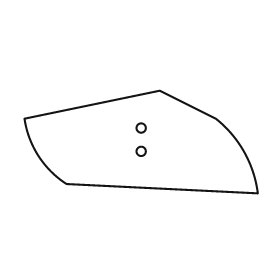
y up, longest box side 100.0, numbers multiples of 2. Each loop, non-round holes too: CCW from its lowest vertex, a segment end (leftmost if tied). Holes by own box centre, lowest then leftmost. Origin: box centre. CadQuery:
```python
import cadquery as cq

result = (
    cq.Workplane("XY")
    .moveTo(50.0, -22.0)
    .threePointArc((44.0, -4.0), (32.0, 10.0))
    .lineTo(8.0, 22.0)
    .lineTo(-50.0, 10.0)
    .threePointArc((-44.0, -6.0), (-32.0, -18.0))
    .close()
    .moveTo(0.0, -4.0)
    .circle(2.0)
    .moveTo(0.0, 6.0)
    .circle(2.0)
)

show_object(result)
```